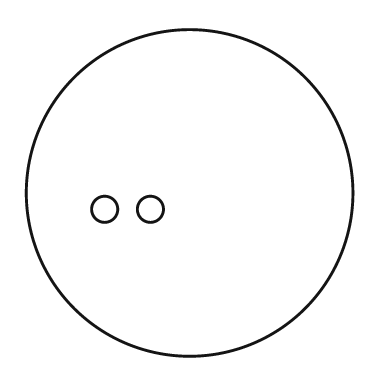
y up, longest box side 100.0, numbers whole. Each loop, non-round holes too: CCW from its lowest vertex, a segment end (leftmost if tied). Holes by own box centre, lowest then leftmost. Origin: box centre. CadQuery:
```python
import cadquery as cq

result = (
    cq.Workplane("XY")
    .moveTo(0.0, 0.0)
    .circle(50.0)
    .moveTo(-26.0, -5.0)
    .circle(4.0)
    .moveTo(-12.0, -5.0)
    .circle(4.0)
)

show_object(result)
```